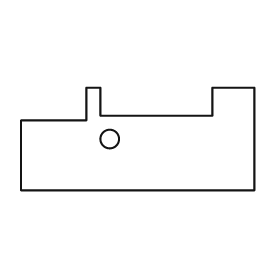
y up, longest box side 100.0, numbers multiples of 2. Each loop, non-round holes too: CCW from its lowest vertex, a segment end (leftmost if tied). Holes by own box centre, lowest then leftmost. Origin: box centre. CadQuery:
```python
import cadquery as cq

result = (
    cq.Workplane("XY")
    .moveTo(-50.0, -22.0)
    .lineTo(50.0, -22.0)
    .lineTo(50.0, 22.0)
    .lineTo(32.0, 22.0)
    .lineTo(32.0, 10.0)
    .lineTo(-16.0, 10.0)
    .lineTo(-16.0, 22.0)
    .lineTo(-22.0, 22.0)
    .lineTo(-22.0, 8.0)
    .lineTo(-50.0, 8.0)
    .close()
    .moveTo(-12.0, 0.0)
    .circle(4.0)
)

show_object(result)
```